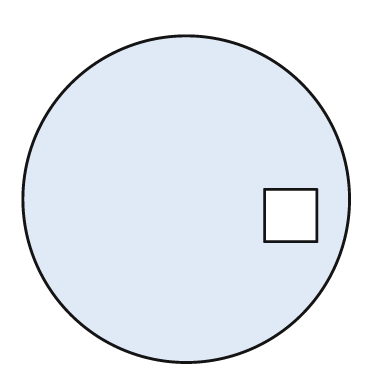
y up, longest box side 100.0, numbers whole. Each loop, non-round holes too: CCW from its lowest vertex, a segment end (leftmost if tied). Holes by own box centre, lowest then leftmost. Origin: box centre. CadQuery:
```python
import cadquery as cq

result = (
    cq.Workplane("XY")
    .moveTo(0.0, 0.0)
    .circle(50.0)
    .moveTo(24.0, -13.0)
    .lineTo(40.0, -13.0)
    .lineTo(40.0, 3.0)
    .lineTo(24.0, 3.0)
    .close()
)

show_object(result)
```